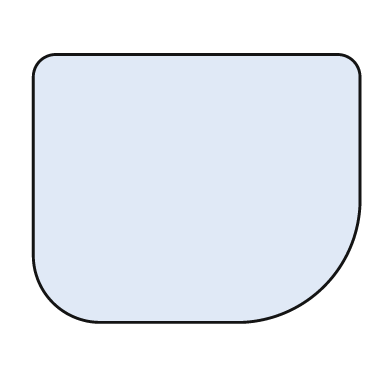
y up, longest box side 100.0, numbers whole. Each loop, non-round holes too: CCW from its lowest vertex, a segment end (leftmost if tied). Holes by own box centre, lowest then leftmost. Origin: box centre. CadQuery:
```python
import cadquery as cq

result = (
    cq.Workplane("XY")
    .moveTo(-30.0, -41.0)
    .lineTo(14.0, -41.0)
    .threePointArc((39.0, -30.0), (50.0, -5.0))
    .lineTo(50.0, 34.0)
    .threePointArc((48.0, 39.0), (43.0, 41.0))
    .lineTo(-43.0, 41.0)
    .threePointArc((-48.0, 39.0), (-50.0, 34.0))
    .lineTo(-50.0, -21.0)
    .threePointArc((-44.0, -35.0), (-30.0, -41.0))
    .close()
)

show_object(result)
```